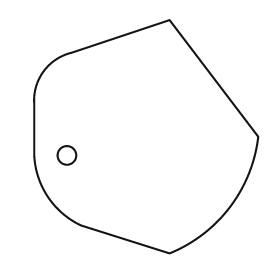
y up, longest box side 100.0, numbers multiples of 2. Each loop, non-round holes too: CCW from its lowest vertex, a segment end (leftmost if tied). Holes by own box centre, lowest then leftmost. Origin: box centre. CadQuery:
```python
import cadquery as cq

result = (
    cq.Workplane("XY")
    .moveTo(10.0, -50.0)
    .threePointArc((36.0, -30.0), (48.0, 0.0))
    .lineTo(10.0, 50.0)
    .lineTo(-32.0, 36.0)
    .threePointArc((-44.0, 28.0), (-48.0, 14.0))
    .lineTo(-48.0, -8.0)
    .threePointArc((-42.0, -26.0), (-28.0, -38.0))
    .close()
    .moveTo(-34.0, -8.0)
    .circle(4.0)
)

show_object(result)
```